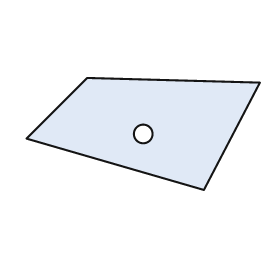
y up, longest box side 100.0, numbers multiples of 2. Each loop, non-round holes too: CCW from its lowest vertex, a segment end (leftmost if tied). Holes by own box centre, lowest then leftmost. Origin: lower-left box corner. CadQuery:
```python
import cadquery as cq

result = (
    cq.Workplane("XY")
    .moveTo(76.0, 0.0)
    .lineTo(100.0, 46.0)
    .lineTo(26.0, 48.0)
    .lineTo(0.0, 22.0)
    .close()
    .moveTo(50.0, 24.0)
    .circle(4.0)
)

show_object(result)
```